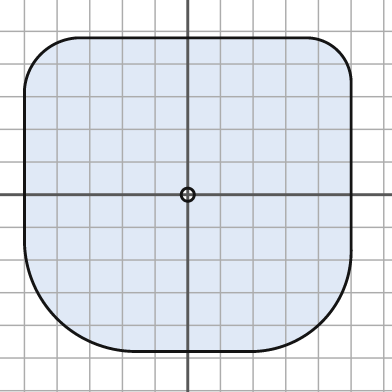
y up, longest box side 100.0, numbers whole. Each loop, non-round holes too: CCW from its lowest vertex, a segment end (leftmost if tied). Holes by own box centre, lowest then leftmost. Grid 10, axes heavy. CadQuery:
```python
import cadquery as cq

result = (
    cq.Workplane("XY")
    .moveTo(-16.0, -48.0)
    .lineTo(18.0, -48.0)
    .threePointArc((41.0, -39.0), (50.0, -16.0))
    .lineTo(50.0, 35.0)
    .threePointArc((46.0, 44.0), (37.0, 48.0))
    .lineTo(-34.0, 48.0)
    .threePointArc((-45.0, 43.0), (-50.0, 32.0))
    .lineTo(-50.0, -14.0)
    .threePointArc((-40.0, -38.0), (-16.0, -48.0))
    .close()
    .moveTo(0.0, 0.0)
    .circle(2.0)
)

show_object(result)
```